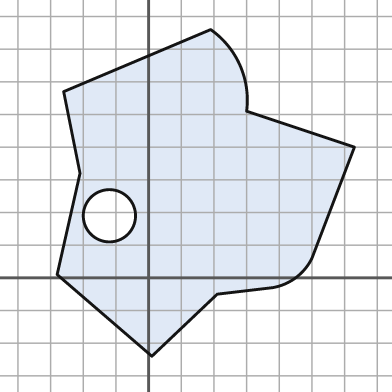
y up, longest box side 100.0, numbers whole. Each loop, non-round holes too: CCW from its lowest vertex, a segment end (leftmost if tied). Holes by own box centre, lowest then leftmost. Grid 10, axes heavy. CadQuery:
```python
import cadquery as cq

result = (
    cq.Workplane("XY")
    .moveTo(1.0, -24.0)
    .lineTo(21.0, -5.0)
    .lineTo(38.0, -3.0)
    .threePointArc((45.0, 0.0), (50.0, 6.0))
    .lineTo(63.0, 40.0)
    .lineTo(30.0, 51.0)
    .threePointArc((28.0, 65.0), (19.0, 76.0))
    .lineTo(-26.0, 57.0)
    .lineTo(-21.0, 32.0)
    .lineTo(-28.0, 1.0)
    .close()
    .moveTo(-12.0, 19.0)
    .circle(8.0)
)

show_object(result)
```